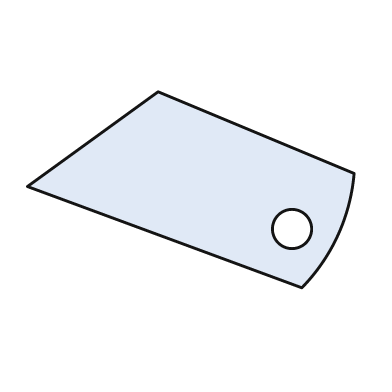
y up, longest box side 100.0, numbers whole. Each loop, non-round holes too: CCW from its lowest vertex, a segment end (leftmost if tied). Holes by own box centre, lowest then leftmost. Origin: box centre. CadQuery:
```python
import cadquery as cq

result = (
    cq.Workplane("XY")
    .moveTo(34.0, -30.0)
    .threePointArc((45.0, -14.0), (50.0, 5.0))
    .lineTo(-10.0, 30.0)
    .lineTo(-50.0, 1.0)
    .close()
    .moveTo(31.0, -12.0)
    .circle(6.0)
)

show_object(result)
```